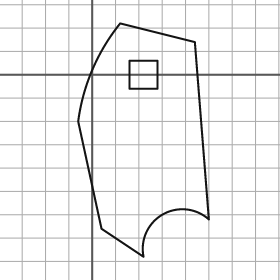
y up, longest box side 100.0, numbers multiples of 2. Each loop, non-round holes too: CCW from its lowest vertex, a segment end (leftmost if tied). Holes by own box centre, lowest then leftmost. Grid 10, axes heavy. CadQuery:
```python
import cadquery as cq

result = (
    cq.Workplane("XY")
    .moveTo(22.0, -78.0)
    .threePointArc((30.0, -60.0), (50.0, -62.0))
    .lineTo(44.0, 14.0)
    .lineTo(12.0, 22.0)
    .threePointArc((0.0, 2.0), (-6.0, -20.0))
    .lineTo(4.0, -66.0)
    .close()
    .moveTo(16.0, -6.0)
    .lineTo(28.0, -6.0)
    .lineTo(28.0, 6.0)
    .lineTo(16.0, 6.0)
    .close()
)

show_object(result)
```